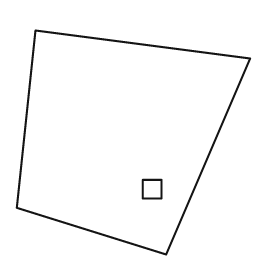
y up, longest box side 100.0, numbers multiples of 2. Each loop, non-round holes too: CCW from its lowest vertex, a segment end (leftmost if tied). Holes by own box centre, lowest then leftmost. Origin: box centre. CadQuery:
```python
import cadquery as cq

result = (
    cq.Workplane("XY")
    .moveTo(14.0, -48.0)
    .lineTo(50.0, 36.0)
    .lineTo(-42.0, 48.0)
    .lineTo(-50.0, -28.0)
    .close()
    .moveTo(4.0, -24.0)
    .lineTo(12.0, -24.0)
    .lineTo(12.0, -16.0)
    .lineTo(4.0, -16.0)
    .close()
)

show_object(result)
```